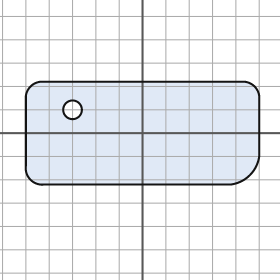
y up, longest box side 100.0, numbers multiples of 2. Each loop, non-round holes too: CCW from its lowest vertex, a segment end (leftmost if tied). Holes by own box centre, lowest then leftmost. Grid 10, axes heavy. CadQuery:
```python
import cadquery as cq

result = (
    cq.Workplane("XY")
    .moveTo(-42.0, -22.0)
    .lineTo(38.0, -22.0)
    .threePointArc((46.0, -18.0), (50.0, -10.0))
    .lineTo(50.0, 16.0)
    .threePointArc((48.0, 20.0), (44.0, 22.0))
    .lineTo(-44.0, 22.0)
    .threePointArc((-48.0, 20.0), (-50.0, 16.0))
    .lineTo(-50.0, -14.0)
    .threePointArc((-48.0, -20.0), (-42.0, -22.0))
    .close()
    .moveTo(-30.0, 10.0)
    .circle(4.0)
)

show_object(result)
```